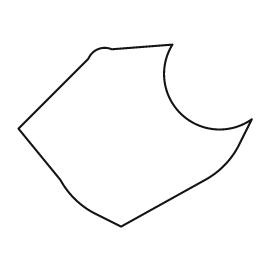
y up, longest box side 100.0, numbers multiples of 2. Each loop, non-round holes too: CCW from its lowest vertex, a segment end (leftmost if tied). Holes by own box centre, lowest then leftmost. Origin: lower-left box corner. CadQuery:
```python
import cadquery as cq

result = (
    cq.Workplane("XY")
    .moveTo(44.0, 0.0)
    .lineTo(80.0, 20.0)
    .threePointArc((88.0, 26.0), (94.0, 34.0))
    .lineTo(100.0, 46.0)
    .threePointArc((70.0, 48.0), (66.0, 78.0))
    .lineTo(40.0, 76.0)
    .threePointArc((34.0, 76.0), (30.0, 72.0))
    .lineTo(0.0, 42.0)
    .lineTo(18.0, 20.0)
    .threePointArc((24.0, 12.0), (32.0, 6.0))
    .close()
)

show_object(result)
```